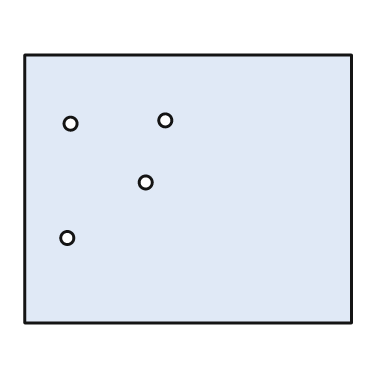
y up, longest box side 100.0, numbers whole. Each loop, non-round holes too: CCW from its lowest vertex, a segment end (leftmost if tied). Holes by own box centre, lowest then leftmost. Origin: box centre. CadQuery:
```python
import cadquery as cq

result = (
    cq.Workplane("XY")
    .moveTo(-50.0, -41.0)
    .lineTo(50.0, -41.0)
    .lineTo(50.0, 41.0)
    .lineTo(-50.0, 41.0)
    .close()
    .moveTo(-37.0, -15.0)
    .circle(2.0)
    .moveTo(-13.0, 2.0)
    .circle(2.0)
    .moveTo(-36.0, 20.0)
    .circle(2.0)
    .moveTo(-7.0, 21.0)
    .circle(2.0)
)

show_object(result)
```